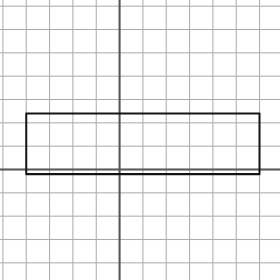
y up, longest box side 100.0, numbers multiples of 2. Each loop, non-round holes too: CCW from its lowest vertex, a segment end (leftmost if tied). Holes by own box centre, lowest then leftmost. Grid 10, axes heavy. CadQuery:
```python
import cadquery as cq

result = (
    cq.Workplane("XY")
    .moveTo(-40.0, -2.0)
    .lineTo(60.0, -2.0)
    .lineTo(60.0, 24.0)
    .lineTo(-40.0, 24.0)
    .close()
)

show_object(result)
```